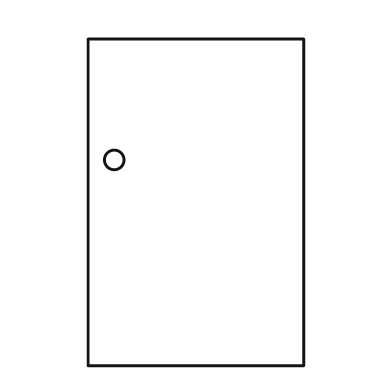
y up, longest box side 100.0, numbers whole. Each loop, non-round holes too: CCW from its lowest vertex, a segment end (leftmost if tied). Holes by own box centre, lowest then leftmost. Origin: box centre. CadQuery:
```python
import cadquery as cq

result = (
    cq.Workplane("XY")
    .moveTo(-33.0, -50.0)
    .lineTo(33.0, -50.0)
    .lineTo(33.0, 50.0)
    .lineTo(-33.0, 50.0)
    .close()
    .moveTo(-25.0, 13.0)
    .circle(3.0)
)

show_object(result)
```